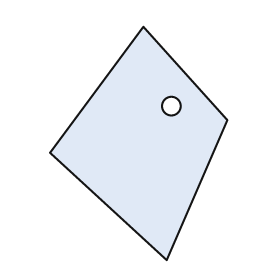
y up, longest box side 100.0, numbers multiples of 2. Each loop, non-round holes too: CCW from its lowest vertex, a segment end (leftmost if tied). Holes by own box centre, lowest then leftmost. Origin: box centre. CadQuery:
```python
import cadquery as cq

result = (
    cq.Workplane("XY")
    .moveTo(12.0, -50.0)
    .lineTo(38.0, 10.0)
    .lineTo(2.0, 50.0)
    .lineTo(-38.0, -4.0)
    .close()
    .moveTo(14.0, 16.0)
    .circle(4.0)
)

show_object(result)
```